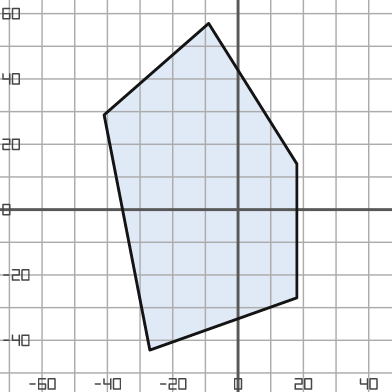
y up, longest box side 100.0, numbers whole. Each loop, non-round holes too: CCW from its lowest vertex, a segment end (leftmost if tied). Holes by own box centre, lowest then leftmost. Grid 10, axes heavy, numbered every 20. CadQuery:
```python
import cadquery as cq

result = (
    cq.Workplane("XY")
    .moveTo(-27.0, -43.0)
    .lineTo(18.0, -27.0)
    .lineTo(18.0, 14.0)
    .lineTo(-9.0, 57.0)
    .lineTo(-41.0, 29.0)
    .close()
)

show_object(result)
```